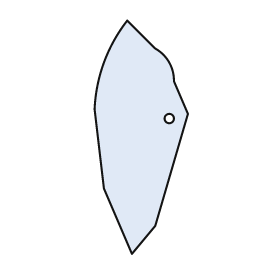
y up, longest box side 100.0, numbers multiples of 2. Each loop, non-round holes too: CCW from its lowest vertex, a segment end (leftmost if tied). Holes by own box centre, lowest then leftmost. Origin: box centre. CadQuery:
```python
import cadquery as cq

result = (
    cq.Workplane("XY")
    .moveTo(-4.0, -50.0)
    .lineTo(6.0, -38.0)
    .lineTo(20.0, 10.0)
    .lineTo(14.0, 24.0)
    .threePointArc((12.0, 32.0), (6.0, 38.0))
    .lineTo(-6.0, 50.0)
    .threePointArc((-16.0, 32.0), (-20.0, 12.0))
    .lineTo(-16.0, -22.0)
    .close()
    .moveTo(12.0, 8.0)
    .circle(2.0)
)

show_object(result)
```